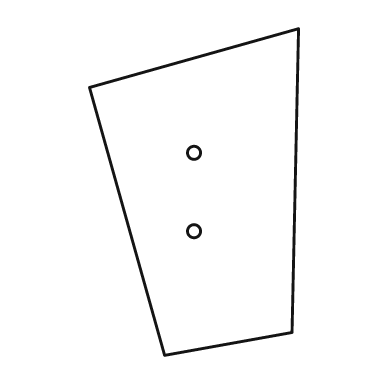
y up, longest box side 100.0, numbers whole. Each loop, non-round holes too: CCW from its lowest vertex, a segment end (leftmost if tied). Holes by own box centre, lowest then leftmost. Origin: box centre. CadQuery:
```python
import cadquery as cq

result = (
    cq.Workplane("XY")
    .moveTo(-9.0, -50.0)
    .lineTo(30.0, -43.0)
    .lineTo(32.0, 50.0)
    .lineTo(-32.0, 32.0)
    .close()
    .moveTo(0.0, -12.0)
    .circle(2.0)
    .moveTo(0.0, 12.0)
    .circle(2.0)
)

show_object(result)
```